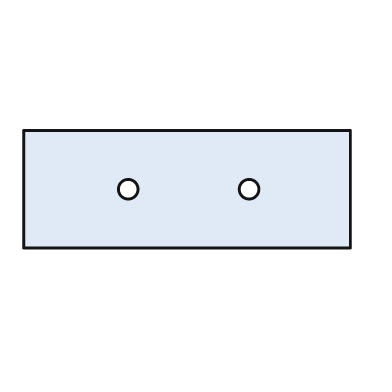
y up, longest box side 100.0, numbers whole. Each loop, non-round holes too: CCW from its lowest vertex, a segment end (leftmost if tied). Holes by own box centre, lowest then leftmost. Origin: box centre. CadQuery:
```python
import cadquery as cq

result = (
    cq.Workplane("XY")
    .moveTo(-50.0, -18.0)
    .lineTo(50.0, -18.0)
    .lineTo(50.0, 18.0)
    .lineTo(-50.0, 18.0)
    .close()
    .moveTo(-18.0, 0.0)
    .circle(3.0)
    .moveTo(19.0, 0.0)
    .circle(3.0)
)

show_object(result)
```